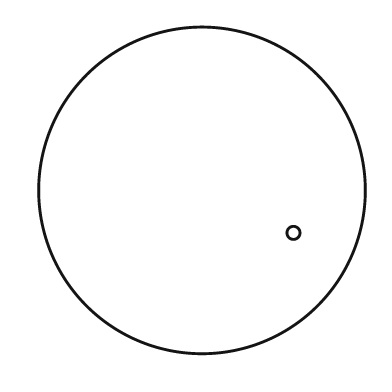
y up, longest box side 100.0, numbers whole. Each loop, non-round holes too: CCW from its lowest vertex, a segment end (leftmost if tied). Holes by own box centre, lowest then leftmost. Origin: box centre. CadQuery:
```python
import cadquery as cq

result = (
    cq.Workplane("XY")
    .moveTo(0.0, 0.0)
    .circle(50.0)
    .moveTo(28.0, -13.0)
    .circle(2.0)
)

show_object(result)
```